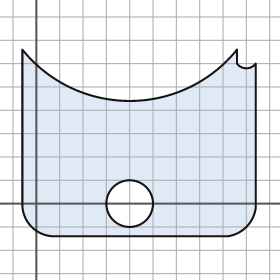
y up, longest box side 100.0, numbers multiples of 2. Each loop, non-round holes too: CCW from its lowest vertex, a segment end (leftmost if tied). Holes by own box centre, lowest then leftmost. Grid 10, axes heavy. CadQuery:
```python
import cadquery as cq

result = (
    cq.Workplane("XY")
    .moveTo(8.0, -14.0)
    .lineTo(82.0, -14.0)
    .threePointArc((90.0, -10.0), (94.0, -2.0))
    .lineTo(94.0, 60.0)
    .threePointArc((90.0, 58.0), (86.0, 60.0))
    .lineTo(86.0, 66.0)
    .threePointArc((40.0, 44.0), (-6.0, 66.0))
    .lineTo(-6.0, 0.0)
    .threePointArc((-2.0, -10.0), (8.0, -14.0))
    .close()
    .moveTo(40.0, 0.0)
    .circle(10.0)
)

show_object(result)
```